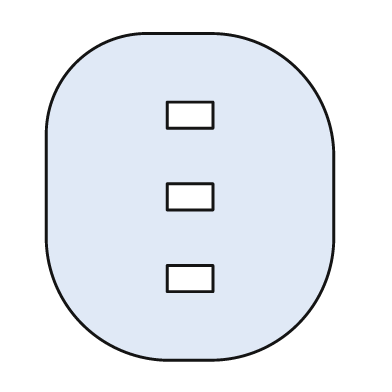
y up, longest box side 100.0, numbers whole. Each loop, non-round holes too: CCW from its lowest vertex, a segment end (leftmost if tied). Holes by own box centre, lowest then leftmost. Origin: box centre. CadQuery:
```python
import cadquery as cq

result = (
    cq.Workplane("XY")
    .moveTo(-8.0, -50.0)
    .lineTo(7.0, -50.0)
    .threePointArc((33.0, -39.0), (44.0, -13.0))
    .lineTo(44.0, 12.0)
    .threePointArc((33.0, 39.0), (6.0, 50.0))
    .lineTo(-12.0, 50.0)
    .threePointArc((-35.0, 41.0), (-44.0, 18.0))
    .lineTo(-44.0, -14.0)
    .threePointArc((-33.0, -39.0), (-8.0, -50.0))
    .close()
    .moveTo(-7.0, -29.0)
    .lineTo(7.0, -29.0)
    .lineTo(7.0, -21.0)
    .lineTo(-7.0, -21.0)
    .close()
    .moveTo(-7.0, -4.0)
    .lineTo(7.0, -4.0)
    .lineTo(7.0, 4.0)
    .lineTo(-7.0, 4.0)
    .close()
    .moveTo(-7.0, 21.0)
    .lineTo(7.0, 21.0)
    .lineTo(7.0, 29.0)
    .lineTo(-7.0, 29.0)
    .close()
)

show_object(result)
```